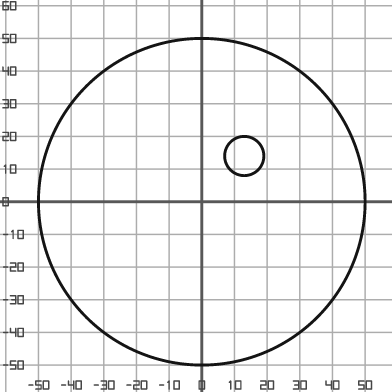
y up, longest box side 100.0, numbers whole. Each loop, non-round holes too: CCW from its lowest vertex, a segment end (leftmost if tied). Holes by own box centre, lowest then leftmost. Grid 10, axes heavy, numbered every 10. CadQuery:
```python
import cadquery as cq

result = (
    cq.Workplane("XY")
    .moveTo(0.0, 0.0)
    .circle(50.0)
    .moveTo(13.0, 14.0)
    .circle(6.0)
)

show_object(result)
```